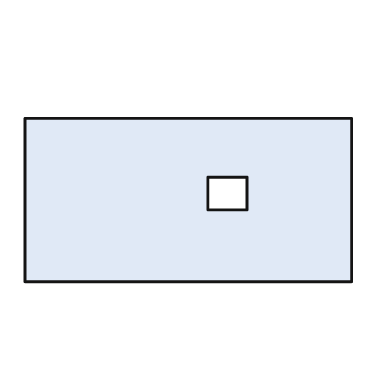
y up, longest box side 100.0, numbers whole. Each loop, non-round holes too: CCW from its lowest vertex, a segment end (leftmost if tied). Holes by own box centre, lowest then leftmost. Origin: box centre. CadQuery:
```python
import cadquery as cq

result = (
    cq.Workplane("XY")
    .moveTo(-50.0, -25.0)
    .lineTo(50.0, -25.0)
    .lineTo(50.0, 25.0)
    .lineTo(-50.0, 25.0)
    .close()
    .moveTo(6.0, -3.0)
    .lineTo(18.0, -3.0)
    .lineTo(18.0, 7.0)
    .lineTo(6.0, 7.0)
    .close()
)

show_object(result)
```